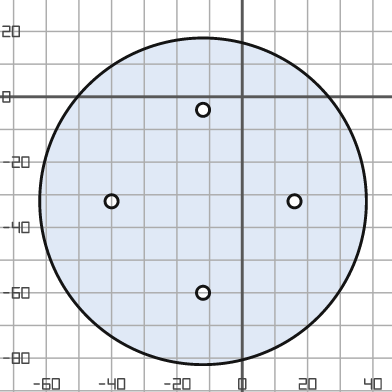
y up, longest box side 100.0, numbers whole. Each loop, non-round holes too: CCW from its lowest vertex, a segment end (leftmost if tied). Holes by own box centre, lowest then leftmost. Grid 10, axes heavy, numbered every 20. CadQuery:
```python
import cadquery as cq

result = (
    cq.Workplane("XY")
    .moveTo(-12.0, -32.0)
    .circle(50.0)
    .moveTo(-12.0, -60.0)
    .circle(2.0)
    .moveTo(-40.0, -32.0)
    .circle(2.0)
    .moveTo(16.0, -32.0)
    .circle(2.0)
    .moveTo(-12.0, -4.0)
    .circle(2.0)
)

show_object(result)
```